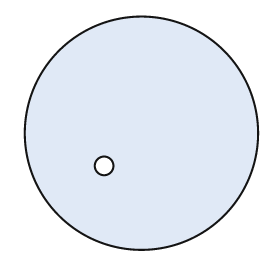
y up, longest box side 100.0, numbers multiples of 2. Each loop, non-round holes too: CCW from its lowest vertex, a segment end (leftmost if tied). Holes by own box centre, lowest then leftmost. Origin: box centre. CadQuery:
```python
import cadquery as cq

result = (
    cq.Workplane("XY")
    .moveTo(0.0, 0.0)
    .circle(50.0)
    .moveTo(-16.0, -14.0)
    .circle(4.0)
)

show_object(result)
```